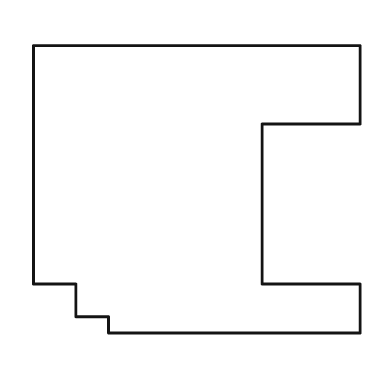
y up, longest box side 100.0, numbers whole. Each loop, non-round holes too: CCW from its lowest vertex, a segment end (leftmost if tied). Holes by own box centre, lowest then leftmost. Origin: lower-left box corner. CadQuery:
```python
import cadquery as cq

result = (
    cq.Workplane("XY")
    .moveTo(23.0, 0.0)
    .lineTo(100.0, 0.0)
    .lineTo(100.0, 15.0)
    .lineTo(70.0, 15.0)
    .lineTo(70.0, 64.0)
    .lineTo(100.0, 64.0)
    .lineTo(100.0, 88.0)
    .lineTo(0.0, 88.0)
    .lineTo(0.0, 15.0)
    .lineTo(13.0, 15.0)
    .lineTo(13.0, 5.0)
    .lineTo(23.0, 5.0)
    .close()
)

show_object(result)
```